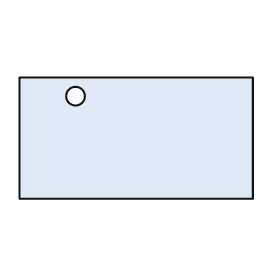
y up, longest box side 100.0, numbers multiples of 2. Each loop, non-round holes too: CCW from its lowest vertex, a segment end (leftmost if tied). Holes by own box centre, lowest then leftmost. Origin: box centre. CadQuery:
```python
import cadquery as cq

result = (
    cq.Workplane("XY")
    .moveTo(-50.0, -26.0)
    .lineTo(50.0, -26.0)
    .lineTo(50.0, 26.0)
    .lineTo(-50.0, 26.0)
    .close()
    .moveTo(-26.0, 18.0)
    .circle(4.0)
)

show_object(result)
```